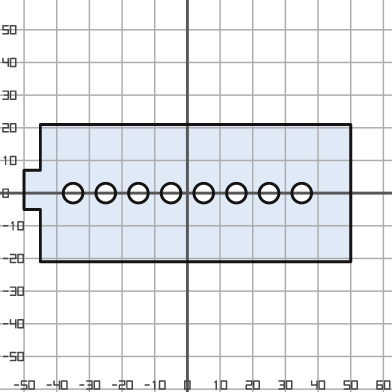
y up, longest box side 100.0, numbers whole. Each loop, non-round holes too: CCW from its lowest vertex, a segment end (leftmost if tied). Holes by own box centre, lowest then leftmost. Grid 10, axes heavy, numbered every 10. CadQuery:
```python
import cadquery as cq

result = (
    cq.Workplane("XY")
    .moveTo(-45.0, -21.0)
    .lineTo(50.0, -21.0)
    .lineTo(50.0, 21.0)
    .lineTo(-45.0, 21.0)
    .lineTo(-45.0, 7.0)
    .lineTo(-50.0, 7.0)
    .lineTo(-50.0, -5.0)
    .lineTo(-45.0, -5.0)
    .close()
    .moveTo(-35.0, 0.0)
    .circle(3.0)
    .moveTo(-25.0, 0.0)
    .circle(3.0)
    .moveTo(-15.0, 0.0)
    .circle(3.0)
    .moveTo(-5.0, 0.0)
    .circle(3.0)
    .moveTo(5.0, 0.0)
    .circle(3.0)
    .moveTo(15.0, 0.0)
    .circle(3.0)
    .moveTo(25.0, 0.0)
    .circle(3.0)
    .moveTo(35.0, 0.0)
    .circle(3.0)
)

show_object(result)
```